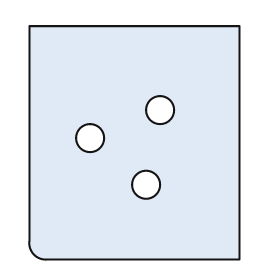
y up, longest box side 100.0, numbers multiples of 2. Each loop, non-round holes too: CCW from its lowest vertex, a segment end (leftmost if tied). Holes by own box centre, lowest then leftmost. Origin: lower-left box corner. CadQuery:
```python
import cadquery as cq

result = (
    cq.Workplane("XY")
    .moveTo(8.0, 0.0)
    .lineTo(90.0, 0.0)
    .lineTo(90.0, 100.0)
    .lineTo(0.0, 100.0)
    .lineTo(0.0, 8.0)
    .threePointArc((2.0, 2.0), (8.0, 0.0))
    .close()
    .moveTo(50.0, 32.0)
    .circle(6.0)
    .moveTo(26.0, 52.0)
    .circle(6.0)
    .moveTo(56.0, 64.0)
    .circle(6.0)
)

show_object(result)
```